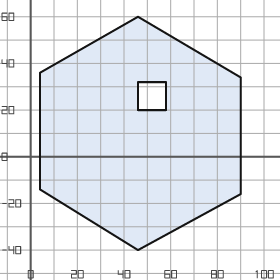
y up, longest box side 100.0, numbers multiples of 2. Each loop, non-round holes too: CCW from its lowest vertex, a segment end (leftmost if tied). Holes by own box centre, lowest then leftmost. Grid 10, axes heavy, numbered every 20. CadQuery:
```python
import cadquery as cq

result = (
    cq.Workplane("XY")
    .moveTo(46.0, -40.0)
    .lineTo(90.0, -16.0)
    .lineTo(90.0, 34.0)
    .lineTo(46.0, 60.0)
    .lineTo(4.0, 36.0)
    .lineTo(4.0, -14.0)
    .close()
    .moveTo(46.0, 20.0)
    .lineTo(58.0, 20.0)
    .lineTo(58.0, 32.0)
    .lineTo(46.0, 32.0)
    .close()
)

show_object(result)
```